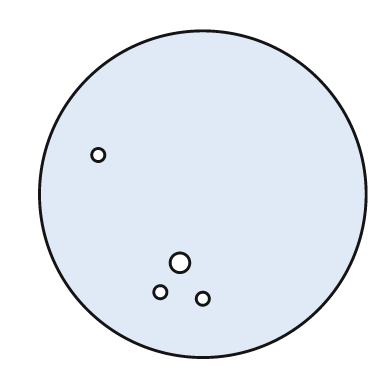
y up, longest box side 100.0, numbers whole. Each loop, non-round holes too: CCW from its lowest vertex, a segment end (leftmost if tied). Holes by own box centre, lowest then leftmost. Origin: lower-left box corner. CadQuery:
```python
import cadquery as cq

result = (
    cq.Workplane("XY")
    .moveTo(50.0, 50.0)
    .circle(50.0)
    .moveTo(50.0, 18.0)
    .circle(2.0)
    .moveTo(37.0, 20.0)
    .circle(2.0)
    .moveTo(43.0, 29.0)
    .circle(3.0)
    .moveTo(18.0, 62.0)
    .circle(2.0)
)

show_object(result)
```